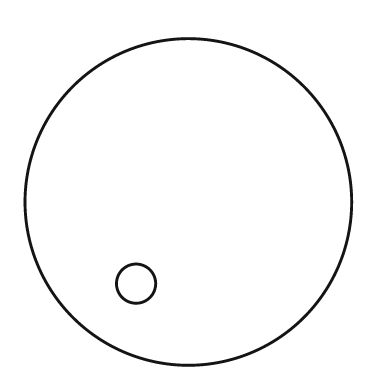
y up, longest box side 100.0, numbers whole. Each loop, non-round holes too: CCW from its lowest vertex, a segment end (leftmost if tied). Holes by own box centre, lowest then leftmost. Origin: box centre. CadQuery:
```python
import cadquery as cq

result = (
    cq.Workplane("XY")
    .moveTo(0.0, 0.0)
    .circle(50.0)
    .moveTo(-16.0, -25.0)
    .circle(6.0)
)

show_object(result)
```